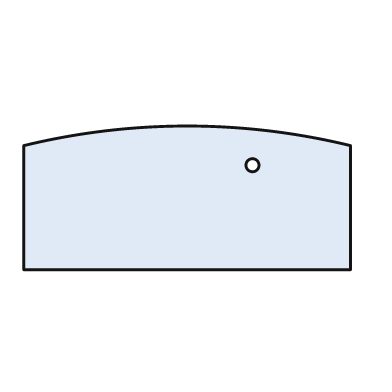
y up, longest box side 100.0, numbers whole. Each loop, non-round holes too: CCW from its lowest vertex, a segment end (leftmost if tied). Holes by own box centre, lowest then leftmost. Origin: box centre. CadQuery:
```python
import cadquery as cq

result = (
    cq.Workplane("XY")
    .moveTo(-50.0, -22.0)
    .lineTo(50.0, -22.0)
    .lineTo(50.0, 16.0)
    .threePointArc((0.0, 22.0), (-50.0, 16.0))
    .close()
    .moveTo(20.0, 10.0)
    .circle(2.0)
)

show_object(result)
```